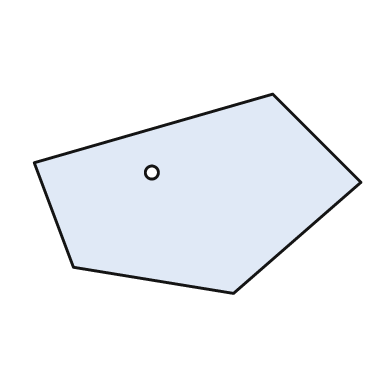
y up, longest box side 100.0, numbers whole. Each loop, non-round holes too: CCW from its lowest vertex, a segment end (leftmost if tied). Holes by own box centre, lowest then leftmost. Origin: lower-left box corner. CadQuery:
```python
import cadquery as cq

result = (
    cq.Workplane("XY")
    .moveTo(61.0, 0.0)
    .lineTo(100.0, 34.0)
    .lineTo(73.0, 61.0)
    .lineTo(0.0, 40.0)
    .lineTo(12.0, 8.0)
    .close()
    .moveTo(36.0, 37.0)
    .circle(2.0)
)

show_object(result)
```